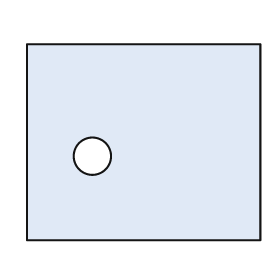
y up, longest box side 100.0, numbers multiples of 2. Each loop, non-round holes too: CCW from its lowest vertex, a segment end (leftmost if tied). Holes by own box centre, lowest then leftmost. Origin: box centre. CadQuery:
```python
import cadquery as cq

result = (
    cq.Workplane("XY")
    .moveTo(-50.0, -42.0)
    .lineTo(50.0, -42.0)
    .lineTo(50.0, 42.0)
    .lineTo(-50.0, 42.0)
    .close()
    .moveTo(-22.0, -6.0)
    .circle(8.0)
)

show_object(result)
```